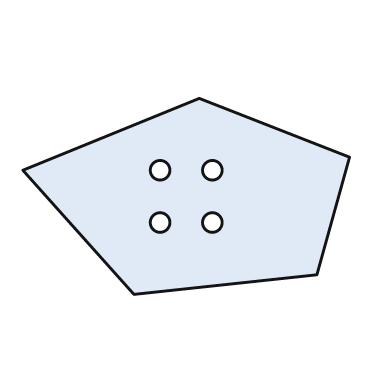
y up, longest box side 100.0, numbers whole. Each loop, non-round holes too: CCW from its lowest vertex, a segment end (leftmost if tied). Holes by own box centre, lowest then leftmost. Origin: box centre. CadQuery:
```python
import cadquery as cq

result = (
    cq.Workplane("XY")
    .moveTo(-16.0, -30.0)
    .lineTo(40.0, -24.0)
    .lineTo(50.0, 12.0)
    .lineTo(4.0, 30.0)
    .lineTo(-50.0, 8.0)
    .close()
    .moveTo(-8.0, -8.0)
    .circle(3.0)
    .moveTo(8.0, -8.0)
    .circle(3.0)
    .moveTo(-8.0, 8.0)
    .circle(3.0)
    .moveTo(8.0, 8.0)
    .circle(3.0)
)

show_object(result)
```